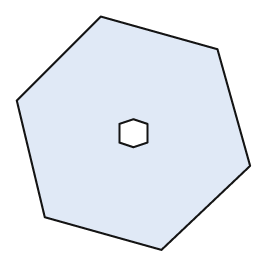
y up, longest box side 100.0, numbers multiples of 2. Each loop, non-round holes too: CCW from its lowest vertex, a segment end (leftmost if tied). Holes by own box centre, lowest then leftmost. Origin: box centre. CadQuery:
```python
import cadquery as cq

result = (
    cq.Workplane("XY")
    .moveTo(12.0, -50.0)
    .lineTo(50.0, -14.0)
    .lineTo(36.0, 36.0)
    .lineTo(-14.0, 50.0)
    .lineTo(-50.0, 14.0)
    .lineTo(-38.0, -36.0)
    .close()
    .moveTo(0.0, -6.0)
    .lineTo(6.0, -4.0)
    .lineTo(6.0, 4.0)
    .lineTo(0.0, 6.0)
    .lineTo(-6.0, 4.0)
    .lineTo(-6.0, -4.0)
    .close()
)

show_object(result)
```